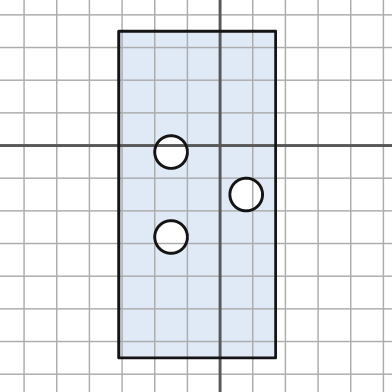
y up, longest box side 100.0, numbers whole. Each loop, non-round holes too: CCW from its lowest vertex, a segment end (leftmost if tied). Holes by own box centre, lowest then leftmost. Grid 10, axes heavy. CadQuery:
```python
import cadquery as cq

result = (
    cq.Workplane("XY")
    .moveTo(-31.0, -65.0)
    .lineTo(17.0, -65.0)
    .lineTo(17.0, 35.0)
    .lineTo(-31.0, 35.0)
    .close()
    .moveTo(-15.0, -28.0)
    .circle(5.0)
    .moveTo(8.0, -15.0)
    .circle(5.0)
    .moveTo(-15.0, -2.0)
    .circle(5.0)
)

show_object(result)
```